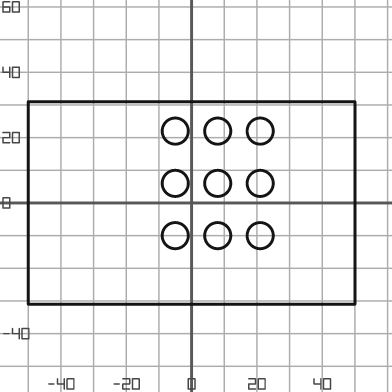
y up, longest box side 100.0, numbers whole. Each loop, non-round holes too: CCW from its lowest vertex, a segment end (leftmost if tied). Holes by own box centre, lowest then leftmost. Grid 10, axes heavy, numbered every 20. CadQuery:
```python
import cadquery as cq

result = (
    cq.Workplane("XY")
    .moveTo(-50.0, -31.0)
    .lineTo(50.0, -31.0)
    .lineTo(50.0, 31.0)
    .lineTo(-50.0, 31.0)
    .close()
    .moveTo(-5.0, -10.0)
    .circle(4.0)
    .moveTo(8.0, -10.0)
    .circle(4.0)
    .moveTo(21.0, -10.0)
    .circle(4.0)
    .moveTo(-5.0, 6.0)
    .circle(4.0)
    .moveTo(8.0, 6.0)
    .circle(4.0)
    .moveTo(21.0, 6.0)
    .circle(4.0)
    .moveTo(-5.0, 22.0)
    .circle(4.0)
    .moveTo(8.0, 22.0)
    .circle(4.0)
    .moveTo(21.0, 22.0)
    .circle(4.0)
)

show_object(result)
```